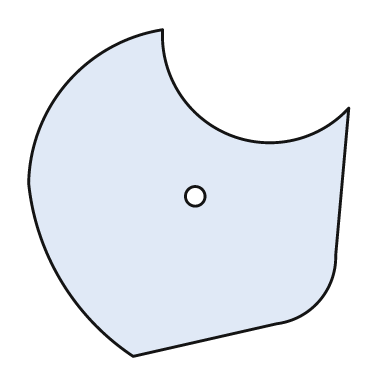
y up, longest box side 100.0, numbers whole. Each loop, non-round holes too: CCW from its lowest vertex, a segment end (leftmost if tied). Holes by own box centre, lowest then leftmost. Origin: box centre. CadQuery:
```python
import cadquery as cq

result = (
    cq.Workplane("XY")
    .moveTo(-17.0, -50.0)
    .lineTo(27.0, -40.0)
    .threePointArc((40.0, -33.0), (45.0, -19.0))
    .lineTo(49.0, 26.0)
    .threePointArc((12.0, 18.0), (-8.0, 50.0))
    .threePointArc((-37.0, 34.0), (-49.0, 3.0))
    .threePointArc((-39.0, -27.0), (-17.0, -50.0))
    .close()
    .moveTo(2.0, -1.0)
    .circle(3.0)
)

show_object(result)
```